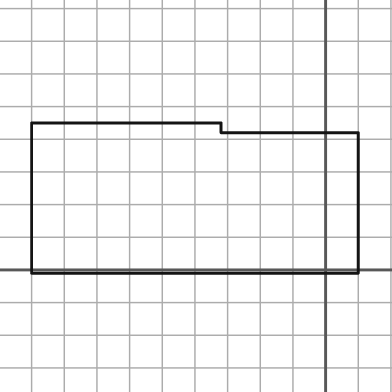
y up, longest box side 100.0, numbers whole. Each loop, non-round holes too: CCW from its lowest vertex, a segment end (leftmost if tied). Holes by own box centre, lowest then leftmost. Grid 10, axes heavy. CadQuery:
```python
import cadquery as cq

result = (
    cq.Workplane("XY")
    .moveTo(-90.0, -1.0)
    .lineTo(10.0, -1.0)
    .lineTo(10.0, 42.0)
    .lineTo(-32.0, 42.0)
    .lineTo(-32.0, 45.0)
    .lineTo(-90.0, 45.0)
    .close()
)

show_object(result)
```